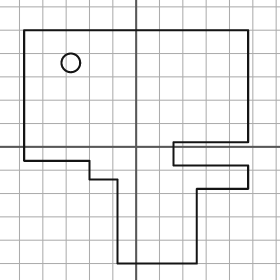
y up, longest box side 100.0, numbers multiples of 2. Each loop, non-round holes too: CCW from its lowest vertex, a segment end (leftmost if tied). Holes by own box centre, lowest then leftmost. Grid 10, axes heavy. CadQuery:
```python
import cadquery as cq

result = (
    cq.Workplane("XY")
    .moveTo(-8.0, -50.0)
    .lineTo(26.0, -50.0)
    .lineTo(26.0, -18.0)
    .lineTo(48.0, -18.0)
    .lineTo(48.0, -8.0)
    .lineTo(16.0, -8.0)
    .lineTo(16.0, 2.0)
    .lineTo(48.0, 2.0)
    .lineTo(48.0, 50.0)
    .lineTo(-48.0, 50.0)
    .lineTo(-48.0, -6.0)
    .lineTo(-20.0, -6.0)
    .lineTo(-20.0, -14.0)
    .lineTo(-8.0, -14.0)
    .close()
    .moveTo(-28.0, 36.0)
    .circle(4.0)
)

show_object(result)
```